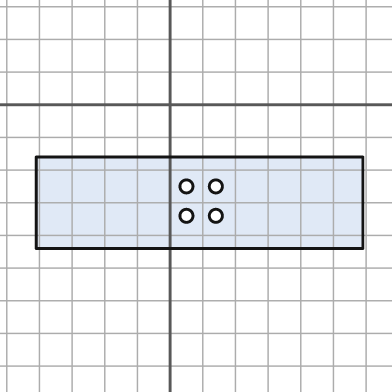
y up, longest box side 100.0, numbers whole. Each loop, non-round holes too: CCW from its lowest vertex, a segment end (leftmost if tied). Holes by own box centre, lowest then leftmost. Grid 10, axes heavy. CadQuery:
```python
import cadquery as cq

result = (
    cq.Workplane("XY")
    .moveTo(-41.0, -44.0)
    .lineTo(59.0, -44.0)
    .lineTo(59.0, -16.0)
    .lineTo(-41.0, -16.0)
    .close()
    .moveTo(5.0, -34.0)
    .circle(2.0)
    .moveTo(14.0, -34.0)
    .circle(2.0)
    .moveTo(5.0, -25.0)
    .circle(2.0)
    .moveTo(14.0, -25.0)
    .circle(2.0)
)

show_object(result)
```